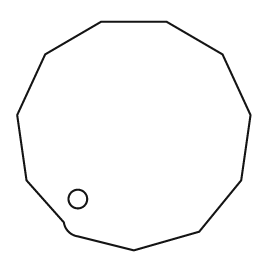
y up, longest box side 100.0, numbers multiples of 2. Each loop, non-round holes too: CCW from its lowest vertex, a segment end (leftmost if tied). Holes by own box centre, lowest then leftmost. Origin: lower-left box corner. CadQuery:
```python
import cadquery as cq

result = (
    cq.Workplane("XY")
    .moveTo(50.0, 0.0)
    .lineTo(78.0, 8.0)
    .lineTo(96.0, 30.0)
    .lineTo(100.0, 58.0)
    .lineTo(88.0, 84.0)
    .lineTo(64.0, 98.0)
    .lineTo(36.0, 98.0)
    .lineTo(12.0, 84.0)
    .lineTo(0.0, 58.0)
    .lineTo(4.0, 30.0)
    .lineTo(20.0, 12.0)
    .threePointArc((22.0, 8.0), (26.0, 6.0))
    .close()
    .moveTo(26.0, 22.0)
    .circle(4.0)
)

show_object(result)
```